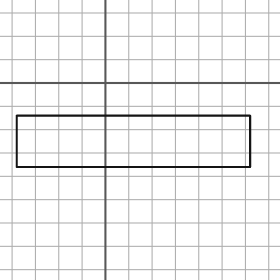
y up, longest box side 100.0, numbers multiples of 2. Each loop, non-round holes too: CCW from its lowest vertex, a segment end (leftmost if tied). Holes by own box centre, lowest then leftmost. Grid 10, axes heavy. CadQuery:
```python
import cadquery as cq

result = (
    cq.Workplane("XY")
    .moveTo(-38.0, -36.0)
    .lineTo(62.0, -36.0)
    .lineTo(62.0, -14.0)
    .lineTo(-38.0, -14.0)
    .close()
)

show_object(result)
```